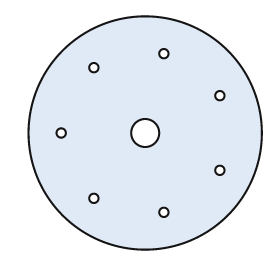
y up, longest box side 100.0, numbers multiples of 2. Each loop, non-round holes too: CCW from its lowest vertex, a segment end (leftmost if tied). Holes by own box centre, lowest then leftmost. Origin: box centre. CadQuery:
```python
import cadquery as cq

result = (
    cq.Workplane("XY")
    .moveTo(0.0, 0.0)
    .circle(50.0)
    .moveTo(8.0, -34.0)
    .circle(2.0)
    .moveTo(-22.0, -28.0)
    .circle(2.0)
    .moveTo(32.0, -16.0)
    .circle(2.0)
    .moveTo(-36.0, 0.0)
    .circle(2.0)
    .moveTo(0.0, 0.0)
    .circle(6.0)
    .moveTo(32.0, 16.0)
    .circle(2.0)
    .moveTo(-22.0, 28.0)
    .circle(2.0)
    .moveTo(8.0, 34.0)
    .circle(2.0)
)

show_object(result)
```